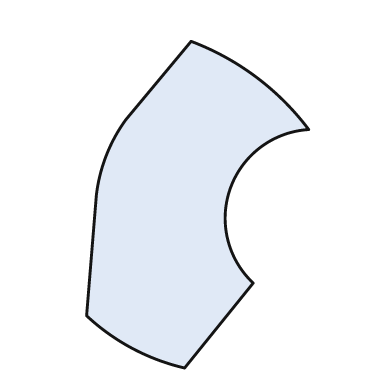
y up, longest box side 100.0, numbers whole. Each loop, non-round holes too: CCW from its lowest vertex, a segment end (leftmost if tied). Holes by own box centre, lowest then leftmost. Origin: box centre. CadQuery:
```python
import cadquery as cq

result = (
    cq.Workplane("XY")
    .moveTo(-4.0, -50.0)
    .lineTo(17.0, -24.0)
    .threePointArc((10.0, 5.0), (34.0, 23.0))
    .threePointArc((18.0, 39.0), (-2.0, 50.0))
    .lineTo(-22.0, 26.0)
    .threePointArc((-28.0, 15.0), (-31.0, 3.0))
    .lineTo(-34.0, -34.0)
    .threePointArc((-20.0, -44.0), (-4.0, -50.0))
    .close()
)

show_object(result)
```